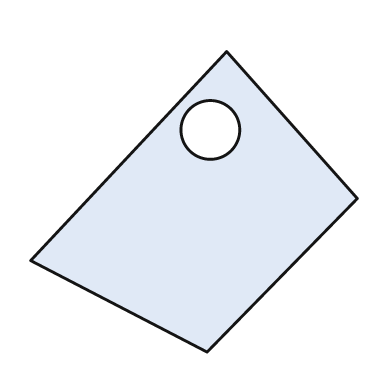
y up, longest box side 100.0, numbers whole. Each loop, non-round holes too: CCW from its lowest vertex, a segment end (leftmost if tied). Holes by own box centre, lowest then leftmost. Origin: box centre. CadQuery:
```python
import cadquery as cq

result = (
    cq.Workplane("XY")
    .moveTo(4.0, -46.0)
    .lineTo(50.0, 1.0)
    .lineTo(10.0, 46.0)
    .lineTo(-50.0, -18.0)
    .close()
    .moveTo(5.0, 22.0)
    .circle(9.0)
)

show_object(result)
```